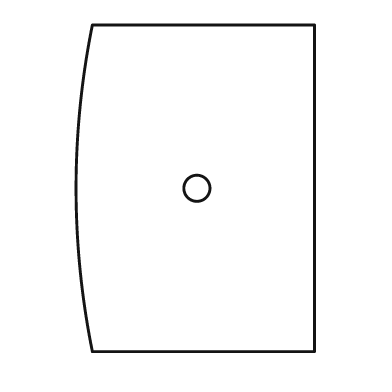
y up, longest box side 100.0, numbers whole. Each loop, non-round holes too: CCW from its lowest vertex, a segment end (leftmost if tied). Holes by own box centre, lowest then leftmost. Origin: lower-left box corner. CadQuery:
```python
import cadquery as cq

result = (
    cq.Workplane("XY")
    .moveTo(5.0, 0.0)
    .lineTo(73.0, 0.0)
    .lineTo(73.0, 100.0)
    .lineTo(5.0, 100.0)
    .threePointArc((0.0, 50.0), (5.0, 0.0))
    .close()
    .moveTo(37.0, 50.0)
    .circle(4.0)
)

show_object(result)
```